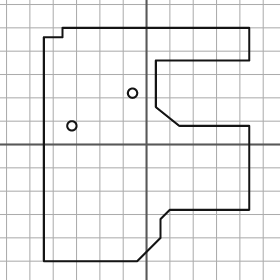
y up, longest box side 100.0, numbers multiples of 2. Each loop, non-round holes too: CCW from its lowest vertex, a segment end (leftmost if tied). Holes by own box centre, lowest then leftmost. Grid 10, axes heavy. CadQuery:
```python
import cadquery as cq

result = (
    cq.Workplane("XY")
    .moveTo(-44.0, -50.0)
    .lineTo(-4.0, -50.0)
    .lineTo(6.0, -40.0)
    .lineTo(6.0, -32.0)
    .lineTo(10.0, -28.0)
    .lineTo(44.0, -28.0)
    .lineTo(44.0, 8.0)
    .lineTo(14.0, 8.0)
    .lineTo(4.0, 16.0)
    .lineTo(4.0, 36.0)
    .lineTo(44.0, 36.0)
    .lineTo(44.0, 50.0)
    .lineTo(-36.0, 50.0)
    .lineTo(-36.0, 46.0)
    .lineTo(-44.0, 46.0)
    .close()
    .moveTo(-32.0, 8.0)
    .circle(2.0)
    .moveTo(-6.0, 22.0)
    .circle(2.0)
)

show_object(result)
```